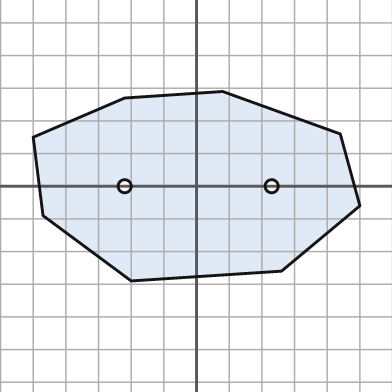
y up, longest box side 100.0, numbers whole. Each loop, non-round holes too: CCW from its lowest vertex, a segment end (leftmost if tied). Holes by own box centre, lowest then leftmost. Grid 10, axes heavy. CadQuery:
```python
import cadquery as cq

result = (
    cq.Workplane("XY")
    .moveTo(-20.0, -29.0)
    .lineTo(26.0, -26.0)
    .lineTo(50.0, -6.0)
    .lineTo(44.0, 16.0)
    .lineTo(8.0, 29.0)
    .lineTo(-22.0, 27.0)
    .lineTo(-50.0, 15.0)
    .lineTo(-47.0, -9.0)
    .close()
    .moveTo(-22.0, 0.0)
    .circle(2.0)
    .moveTo(23.0, 0.0)
    .circle(2.0)
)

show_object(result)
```